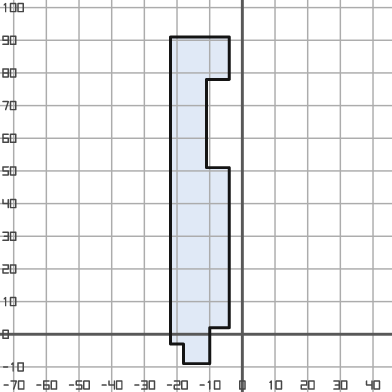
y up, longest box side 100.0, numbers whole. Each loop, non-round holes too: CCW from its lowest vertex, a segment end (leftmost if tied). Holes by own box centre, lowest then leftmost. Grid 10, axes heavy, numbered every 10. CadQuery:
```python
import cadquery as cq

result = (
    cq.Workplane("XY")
    .moveTo(-18.0, -9.0)
    .lineTo(-10.0, -9.0)
    .lineTo(-10.0, 2.0)
    .lineTo(-4.0, 2.0)
    .lineTo(-4.0, 51.0)
    .lineTo(-11.0, 51.0)
    .lineTo(-11.0, 78.0)
    .lineTo(-4.0, 78.0)
    .lineTo(-4.0, 91.0)
    .lineTo(-22.0, 91.0)
    .lineTo(-22.0, -3.0)
    .lineTo(-18.0, -3.0)
    .close()
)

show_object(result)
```